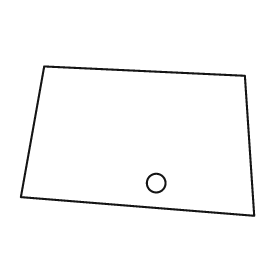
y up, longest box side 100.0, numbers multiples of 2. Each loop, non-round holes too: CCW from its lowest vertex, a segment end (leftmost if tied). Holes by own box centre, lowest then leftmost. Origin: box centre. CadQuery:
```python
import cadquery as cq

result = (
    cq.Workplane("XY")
    .moveTo(50.0, -32.0)
    .lineTo(46.0, 28.0)
    .lineTo(-40.0, 32.0)
    .lineTo(-50.0, -24.0)
    .close()
    .moveTo(8.0, -18.0)
    .circle(4.0)
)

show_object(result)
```